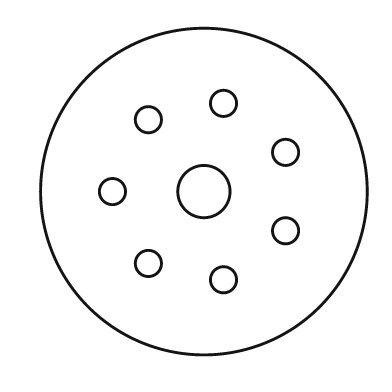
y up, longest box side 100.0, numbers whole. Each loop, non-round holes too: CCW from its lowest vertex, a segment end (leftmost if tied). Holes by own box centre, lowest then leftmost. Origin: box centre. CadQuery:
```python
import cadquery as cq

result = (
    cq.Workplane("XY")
    .moveTo(0.0, 0.0)
    .circle(50.0)
    .moveTo(6.0, -27.0)
    .circle(4.0)
    .moveTo(-17.0, -22.0)
    .circle(4.0)
    .moveTo(25.0, -12.0)
    .circle(4.0)
    .moveTo(-28.0, 0.0)
    .circle(4.0)
    .moveTo(0.0, 0.0)
    .circle(8.0)
    .moveTo(25.0, 12.0)
    .circle(4.0)
    .moveTo(-17.0, 22.0)
    .circle(4.0)
    .moveTo(6.0, 27.0)
    .circle(4.0)
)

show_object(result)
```